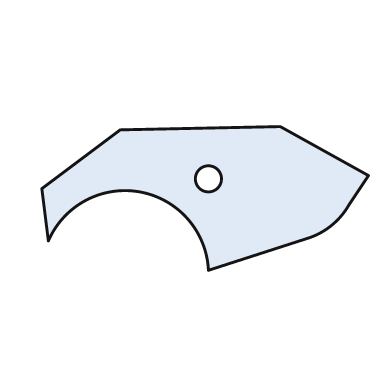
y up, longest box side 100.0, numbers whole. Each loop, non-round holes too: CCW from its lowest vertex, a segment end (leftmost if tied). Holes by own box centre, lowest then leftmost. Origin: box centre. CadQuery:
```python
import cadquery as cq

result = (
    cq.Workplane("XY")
    .moveTo(1.0, -22.0)
    .lineTo(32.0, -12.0)
    .threePointArc((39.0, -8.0), (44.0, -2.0))
    .lineTo(50.0, 7.0)
    .lineTo(23.0, 22.0)
    .lineTo(-26.0, 21.0)
    .lineTo(-50.0, 3.0)
    .lineTo(-48.0, -13.0)
    .threePointArc((-20.0, 2.0), (1.0, -22.0))
    .close()
    .moveTo(1.0, 6.0)
    .circle(4.0)
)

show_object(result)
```